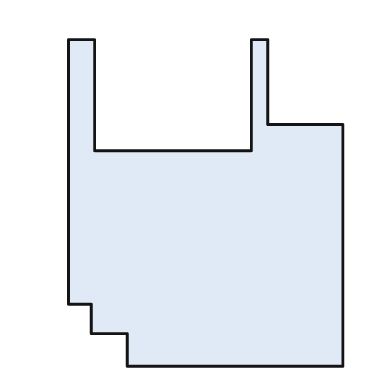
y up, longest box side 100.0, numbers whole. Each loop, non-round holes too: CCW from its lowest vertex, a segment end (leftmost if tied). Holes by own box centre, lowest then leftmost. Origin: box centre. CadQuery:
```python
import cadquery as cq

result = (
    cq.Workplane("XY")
    .moveTo(-24.0, -50.0)
    .lineTo(42.0, -50.0)
    .lineTo(42.0, 24.0)
    .lineTo(19.0, 24.0)
    .lineTo(19.0, 50.0)
    .lineTo(14.0, 50.0)
    .lineTo(14.0, 16.0)
    .lineTo(-34.0, 16.0)
    .lineTo(-34.0, 50.0)
    .lineTo(-42.0, 50.0)
    .lineTo(-42.0, -31.0)
    .lineTo(-35.0, -31.0)
    .lineTo(-35.0, -40.0)
    .lineTo(-24.0, -40.0)
    .close()
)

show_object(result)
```